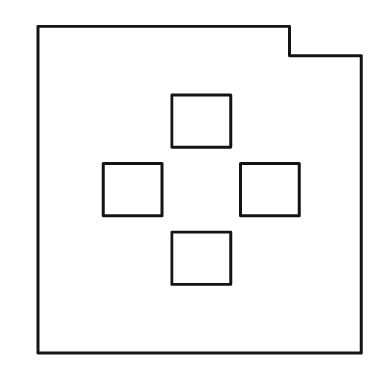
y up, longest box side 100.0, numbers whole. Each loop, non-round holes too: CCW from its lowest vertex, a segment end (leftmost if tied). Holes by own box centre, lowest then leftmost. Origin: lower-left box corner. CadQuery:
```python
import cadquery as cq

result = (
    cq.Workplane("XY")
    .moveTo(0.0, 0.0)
    .lineTo(99.0, 0.0)
    .lineTo(99.0, 91.0)
    .lineTo(77.0, 91.0)
    .lineTo(77.0, 100.0)
    .lineTo(0.0, 100.0)
    .close()
    .moveTo(41.0, 21.0)
    .lineTo(59.0, 21.0)
    .lineTo(59.0, 37.0)
    .lineTo(41.0, 37.0)
    .close()
    .moveTo(20.0, 42.0)
    .lineTo(38.0, 42.0)
    .lineTo(38.0, 58.0)
    .lineTo(20.0, 58.0)
    .close()
    .moveTo(62.0, 42.0)
    .lineTo(80.0, 42.0)
    .lineTo(80.0, 58.0)
    .lineTo(62.0, 58.0)
    .close()
    .moveTo(41.0, 63.0)
    .lineTo(59.0, 63.0)
    .lineTo(59.0, 79.0)
    .lineTo(41.0, 79.0)
    .close()
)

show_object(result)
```